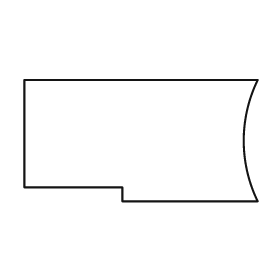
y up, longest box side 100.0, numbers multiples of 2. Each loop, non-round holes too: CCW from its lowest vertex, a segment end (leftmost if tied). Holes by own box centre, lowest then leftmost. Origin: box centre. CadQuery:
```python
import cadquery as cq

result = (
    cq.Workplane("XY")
    .moveTo(-8.0, -26.0)
    .lineTo(50.0, -26.0)
    .threePointArc((44.0, 0.0), (50.0, 26.0))
    .lineTo(-50.0, 26.0)
    .lineTo(-50.0, -20.0)
    .lineTo(-8.0, -20.0)
    .close()
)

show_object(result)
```